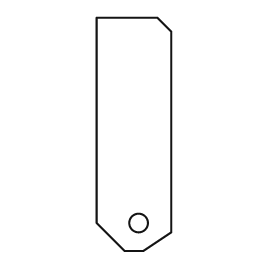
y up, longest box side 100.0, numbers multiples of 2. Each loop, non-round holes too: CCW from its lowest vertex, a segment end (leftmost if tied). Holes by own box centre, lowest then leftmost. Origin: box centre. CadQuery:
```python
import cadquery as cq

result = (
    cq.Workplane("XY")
    .moveTo(-4.0, -50.0)
    .lineTo(4.0, -50.0)
    .lineTo(16.0, -42.0)
    .lineTo(16.0, 44.0)
    .lineTo(10.0, 50.0)
    .lineTo(-16.0, 50.0)
    .lineTo(-16.0, -38.0)
    .close()
    .moveTo(2.0, -38.0)
    .circle(4.0)
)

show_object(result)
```